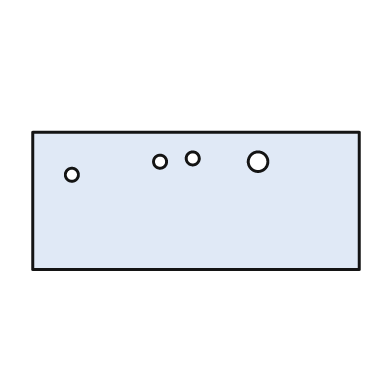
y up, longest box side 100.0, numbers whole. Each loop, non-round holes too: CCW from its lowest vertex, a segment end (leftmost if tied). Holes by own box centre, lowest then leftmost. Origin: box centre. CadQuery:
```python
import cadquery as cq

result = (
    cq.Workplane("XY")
    .moveTo(-50.0, -21.0)
    .lineTo(50.0, -21.0)
    .lineTo(50.0, 21.0)
    .lineTo(-50.0, 21.0)
    .close()
    .moveTo(-38.0, 8.0)
    .circle(2.0)
    .moveTo(-11.0, 12.0)
    .circle(2.0)
    .moveTo(19.0, 12.0)
    .circle(3.0)
    .moveTo(-1.0, 13.0)
    .circle(2.0)
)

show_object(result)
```